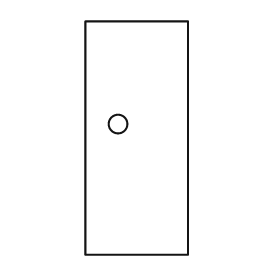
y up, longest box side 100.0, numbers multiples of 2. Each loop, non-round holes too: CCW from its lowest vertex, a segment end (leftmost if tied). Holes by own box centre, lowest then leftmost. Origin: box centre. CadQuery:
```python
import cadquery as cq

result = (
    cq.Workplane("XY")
    .moveTo(-22.0, -50.0)
    .lineTo(22.0, -50.0)
    .lineTo(22.0, 50.0)
    .lineTo(-22.0, 50.0)
    .close()
    .moveTo(-8.0, 6.0)
    .circle(4.0)
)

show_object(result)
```